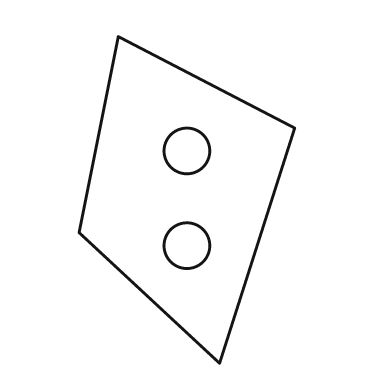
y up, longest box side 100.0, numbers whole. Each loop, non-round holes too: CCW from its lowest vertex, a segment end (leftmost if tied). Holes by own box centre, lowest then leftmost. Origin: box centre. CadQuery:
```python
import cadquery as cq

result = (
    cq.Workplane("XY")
    .moveTo(10.0, -50.0)
    .lineTo(33.0, 22.0)
    .lineTo(-21.0, 50.0)
    .lineTo(-33.0, -10.0)
    .close()
    .moveTo(0.0, -14.0)
    .circle(7.0)
    .moveTo(0.0, 15.0)
    .circle(7.0)
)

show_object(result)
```